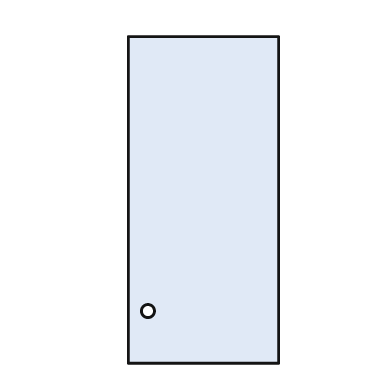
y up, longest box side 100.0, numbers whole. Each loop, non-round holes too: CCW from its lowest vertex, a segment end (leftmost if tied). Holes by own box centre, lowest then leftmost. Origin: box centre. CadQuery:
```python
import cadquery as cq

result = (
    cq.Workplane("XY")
    .moveTo(-23.0, -50.0)
    .lineTo(23.0, -50.0)
    .lineTo(23.0, 50.0)
    .lineTo(-23.0, 50.0)
    .close()
    .moveTo(-17.0, -34.0)
    .circle(2.0)
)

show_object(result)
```